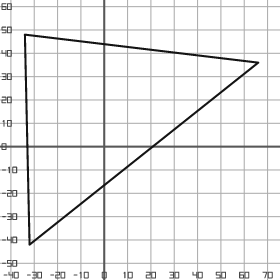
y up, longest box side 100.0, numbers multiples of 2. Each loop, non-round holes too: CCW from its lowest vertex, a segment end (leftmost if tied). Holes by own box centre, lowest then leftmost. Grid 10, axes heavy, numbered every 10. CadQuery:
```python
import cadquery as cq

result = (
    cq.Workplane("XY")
    .moveTo(-32.0, -42.0)
    .lineTo(66.0, 36.0)
    .lineTo(-34.0, 48.0)
    .close()
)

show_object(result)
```